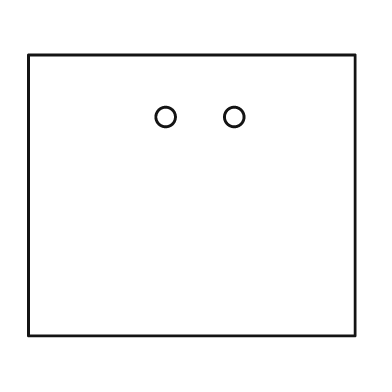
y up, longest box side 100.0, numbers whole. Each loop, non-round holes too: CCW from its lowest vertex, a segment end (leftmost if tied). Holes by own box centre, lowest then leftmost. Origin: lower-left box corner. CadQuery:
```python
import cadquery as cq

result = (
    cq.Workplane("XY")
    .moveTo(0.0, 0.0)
    .lineTo(100.0, 0.0)
    .lineTo(100.0, 86.0)
    .lineTo(0.0, 86.0)
    .close()
    .moveTo(42.0, 67.0)
    .circle(3.0)
    .moveTo(63.0, 67.0)
    .circle(3.0)
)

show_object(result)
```